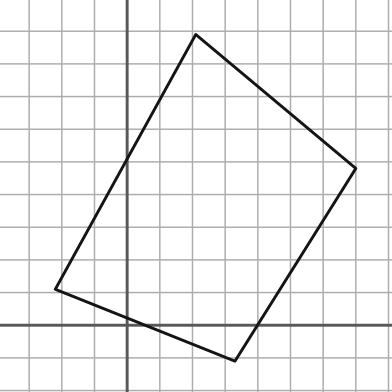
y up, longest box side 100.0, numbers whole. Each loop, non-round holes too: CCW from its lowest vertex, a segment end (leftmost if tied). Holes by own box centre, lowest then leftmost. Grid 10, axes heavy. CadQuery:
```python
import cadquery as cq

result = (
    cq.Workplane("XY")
    .moveTo(33.0, -11.0)
    .lineTo(70.0, 48.0)
    .lineTo(21.0, 89.0)
    .lineTo(-22.0, 11.0)
    .close()
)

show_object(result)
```